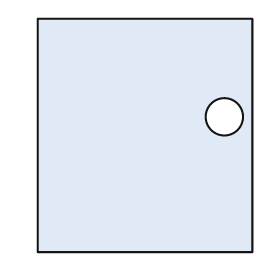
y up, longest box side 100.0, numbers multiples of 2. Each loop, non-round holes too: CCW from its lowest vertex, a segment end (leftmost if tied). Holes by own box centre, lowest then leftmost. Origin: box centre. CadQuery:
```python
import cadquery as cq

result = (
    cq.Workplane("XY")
    .moveTo(-46.0, -50.0)
    .lineTo(46.0, -50.0)
    .lineTo(46.0, 50.0)
    .lineTo(-46.0, 50.0)
    .close()
    .moveTo(34.0, 8.0)
    .circle(8.0)
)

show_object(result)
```